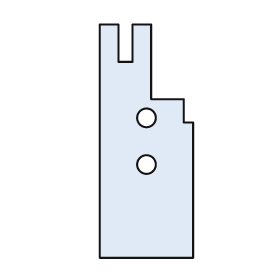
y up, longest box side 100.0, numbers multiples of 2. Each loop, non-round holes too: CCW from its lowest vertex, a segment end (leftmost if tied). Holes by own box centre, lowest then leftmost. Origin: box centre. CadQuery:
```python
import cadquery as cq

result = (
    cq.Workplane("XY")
    .moveTo(-20.0, -50.0)
    .lineTo(20.0, -50.0)
    .lineTo(20.0, 8.0)
    .lineTo(16.0, 8.0)
    .lineTo(16.0, 18.0)
    .lineTo(2.0, 18.0)
    .lineTo(2.0, 50.0)
    .lineTo(-6.0, 50.0)
    .lineTo(-6.0, 34.0)
    .lineTo(-12.0, 34.0)
    .lineTo(-12.0, 50.0)
    .lineTo(-20.0, 50.0)
    .close()
    .moveTo(0.0, -10.0)
    .circle(4.0)
    .moveTo(0.0, 10.0)
    .circle(4.0)
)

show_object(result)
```